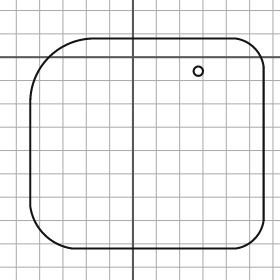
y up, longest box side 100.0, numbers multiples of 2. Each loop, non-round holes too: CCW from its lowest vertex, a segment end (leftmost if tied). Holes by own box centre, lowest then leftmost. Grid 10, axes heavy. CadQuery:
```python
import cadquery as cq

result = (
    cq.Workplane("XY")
    .moveTo(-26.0, -82.0)
    .lineTo(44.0, -82.0)
    .threePointArc((52.0, -78.0), (56.0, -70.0))
    .lineTo(56.0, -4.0)
    .threePointArc((52.0, 4.0), (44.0, 8.0))
    .lineTo(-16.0, 8.0)
    .threePointArc((-36.0, 0.0), (-44.0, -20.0))
    .lineTo(-44.0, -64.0)
    .threePointArc((-38.0, -76.0), (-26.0, -82.0))
    .close()
    .moveTo(28.0, -6.0)
    .circle(2.0)
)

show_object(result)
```